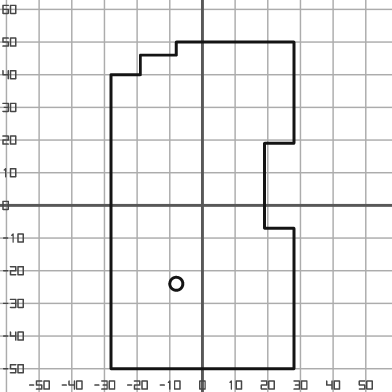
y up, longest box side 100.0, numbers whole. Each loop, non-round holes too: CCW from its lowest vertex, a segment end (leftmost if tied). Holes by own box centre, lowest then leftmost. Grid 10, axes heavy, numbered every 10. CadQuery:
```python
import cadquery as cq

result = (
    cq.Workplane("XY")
    .moveTo(-28.0, -50.0)
    .lineTo(28.0, -50.0)
    .lineTo(28.0, -7.0)
    .lineTo(19.0, -7.0)
    .lineTo(19.0, 19.0)
    .lineTo(28.0, 19.0)
    .lineTo(28.0, 50.0)
    .lineTo(-8.0, 50.0)
    .lineTo(-8.0, 46.0)
    .lineTo(-19.0, 46.0)
    .lineTo(-19.0, 40.0)
    .lineTo(-28.0, 40.0)
    .close()
    .moveTo(-8.0, -24.0)
    .circle(2.0)
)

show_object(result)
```